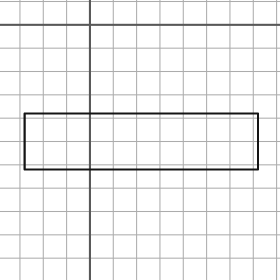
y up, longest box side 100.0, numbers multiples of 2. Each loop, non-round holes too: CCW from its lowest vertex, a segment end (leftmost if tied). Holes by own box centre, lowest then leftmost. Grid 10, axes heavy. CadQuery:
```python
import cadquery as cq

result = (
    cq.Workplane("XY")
    .moveTo(-28.0, -62.0)
    .lineTo(72.0, -62.0)
    .lineTo(72.0, -38.0)
    .lineTo(-28.0, -38.0)
    .close()
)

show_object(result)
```